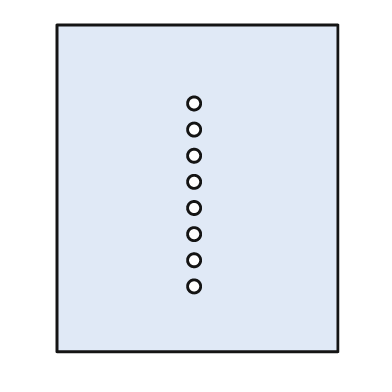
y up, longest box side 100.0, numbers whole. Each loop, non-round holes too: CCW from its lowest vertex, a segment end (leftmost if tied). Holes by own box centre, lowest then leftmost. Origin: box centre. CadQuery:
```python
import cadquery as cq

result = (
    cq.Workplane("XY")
    .moveTo(-43.0, -50.0)
    .lineTo(43.0, -50.0)
    .lineTo(43.0, 50.0)
    .lineTo(-43.0, 50.0)
    .close()
    .moveTo(-1.0, -30.0)
    .circle(2.0)
    .moveTo(-1.0, -22.0)
    .circle(2.0)
    .moveTo(-1.0, -14.0)
    .circle(2.0)
    .moveTo(-1.0, -6.0)
    .circle(2.0)
    .moveTo(-1.0, 2.0)
    .circle(2.0)
    .moveTo(-1.0, 10.0)
    .circle(2.0)
    .moveTo(-1.0, 18.0)
    .circle(2.0)
    .moveTo(-1.0, 26.0)
    .circle(2.0)
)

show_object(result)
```